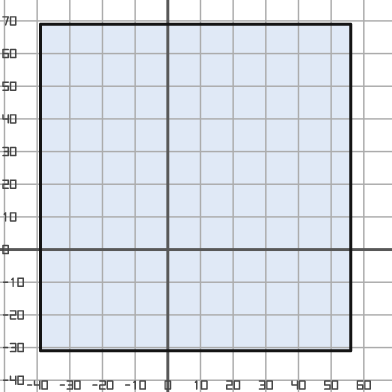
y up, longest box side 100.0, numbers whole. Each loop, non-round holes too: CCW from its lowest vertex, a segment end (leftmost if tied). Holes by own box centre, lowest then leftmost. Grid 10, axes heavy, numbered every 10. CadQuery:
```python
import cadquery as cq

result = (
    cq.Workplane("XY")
    .moveTo(-39.0, -31.0)
    .lineTo(56.0, -31.0)
    .lineTo(56.0, 69.0)
    .lineTo(-39.0, 69.0)
    .close()
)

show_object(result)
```